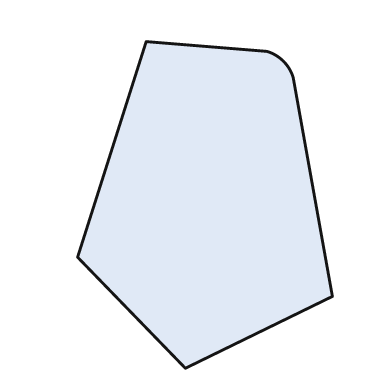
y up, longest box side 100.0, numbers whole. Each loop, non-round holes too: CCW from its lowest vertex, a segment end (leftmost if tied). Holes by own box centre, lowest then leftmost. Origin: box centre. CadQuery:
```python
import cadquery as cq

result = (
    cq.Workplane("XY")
    .moveTo(-6.0, -50.0)
    .lineTo(39.0, -28.0)
    .lineTo(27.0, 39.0)
    .threePointArc((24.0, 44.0), (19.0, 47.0))
    .lineTo(-18.0, 50.0)
    .lineTo(-39.0, -16.0)
    .close()
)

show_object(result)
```